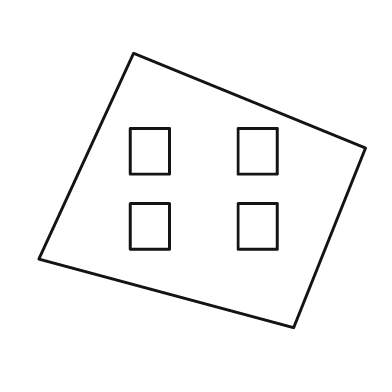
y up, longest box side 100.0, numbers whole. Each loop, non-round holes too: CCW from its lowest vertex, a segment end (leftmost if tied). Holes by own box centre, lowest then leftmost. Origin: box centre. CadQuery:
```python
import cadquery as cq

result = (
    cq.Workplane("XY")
    .moveTo(28.0, -42.0)
    .lineTo(50.0, 13.0)
    .lineTo(-21.0, 42.0)
    .lineTo(-50.0, -21.0)
    .close()
    .moveTo(-22.0, -18.0)
    .lineTo(-10.0, -18.0)
    .lineTo(-10.0, -4.0)
    .lineTo(-22.0, -4.0)
    .close()
    .moveTo(11.0, -18.0)
    .lineTo(23.0, -18.0)
    .lineTo(23.0, -4.0)
    .lineTo(11.0, -4.0)
    .close()
    .moveTo(-22.0, 5.0)
    .lineTo(-10.0, 5.0)
    .lineTo(-10.0, 19.0)
    .lineTo(-22.0, 19.0)
    .close()
    .moveTo(11.0, 5.0)
    .lineTo(23.0, 5.0)
    .lineTo(23.0, 19.0)
    .lineTo(11.0, 19.0)
    .close()
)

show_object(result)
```